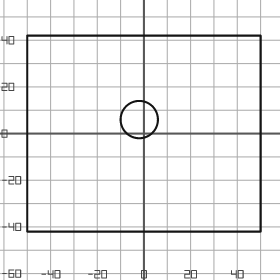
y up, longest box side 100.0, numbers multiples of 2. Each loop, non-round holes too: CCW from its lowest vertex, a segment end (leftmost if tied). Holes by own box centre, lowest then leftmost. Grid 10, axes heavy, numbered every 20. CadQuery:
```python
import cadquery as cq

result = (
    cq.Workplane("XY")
    .moveTo(-50.0, -42.0)
    .lineTo(50.0, -42.0)
    .lineTo(50.0, 42.0)
    .lineTo(-50.0, 42.0)
    .close()
    .moveTo(-2.0, 6.0)
    .circle(8.0)
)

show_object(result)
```